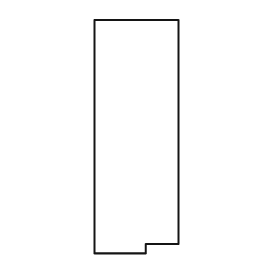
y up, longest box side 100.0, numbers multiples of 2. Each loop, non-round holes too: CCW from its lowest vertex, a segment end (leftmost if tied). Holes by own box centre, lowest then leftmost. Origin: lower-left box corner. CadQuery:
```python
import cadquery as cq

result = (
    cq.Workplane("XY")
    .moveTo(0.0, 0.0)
    .lineTo(22.0, 0.0)
    .lineTo(22.0, 4.0)
    .lineTo(36.0, 4.0)
    .lineTo(36.0, 100.0)
    .lineTo(0.0, 100.0)
    .close()
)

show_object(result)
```